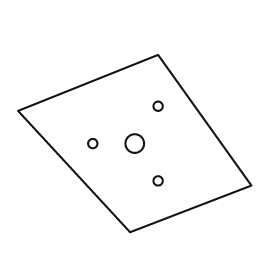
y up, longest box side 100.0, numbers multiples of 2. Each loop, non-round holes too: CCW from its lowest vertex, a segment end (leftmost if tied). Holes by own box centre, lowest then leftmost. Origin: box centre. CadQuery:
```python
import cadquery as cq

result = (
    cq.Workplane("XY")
    .moveTo(-2.0, -38.0)
    .lineTo(50.0, -18.0)
    .lineTo(10.0, 38.0)
    .lineTo(-50.0, 14.0)
    .close()
    .moveTo(10.0, -16.0)
    .circle(2.0)
    .moveTo(-18.0, 0.0)
    .circle(2.0)
    .moveTo(0.0, 0.0)
    .circle(4.0)
    .moveTo(10.0, 16.0)
    .circle(2.0)
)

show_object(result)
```